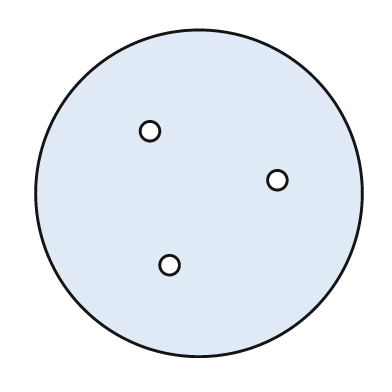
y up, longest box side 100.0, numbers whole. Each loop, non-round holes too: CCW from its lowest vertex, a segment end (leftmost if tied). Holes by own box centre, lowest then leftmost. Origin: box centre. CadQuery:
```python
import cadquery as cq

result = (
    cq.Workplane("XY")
    .moveTo(0.0, 0.0)
    .circle(50.0)
    .moveTo(-9.0, -22.0)
    .circle(3.0)
    .moveTo(24.0, 4.0)
    .circle(3.0)
    .moveTo(-15.0, 19.0)
    .circle(3.0)
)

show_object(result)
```